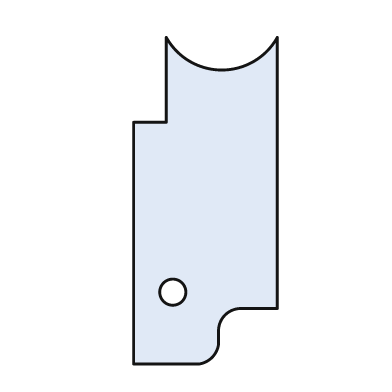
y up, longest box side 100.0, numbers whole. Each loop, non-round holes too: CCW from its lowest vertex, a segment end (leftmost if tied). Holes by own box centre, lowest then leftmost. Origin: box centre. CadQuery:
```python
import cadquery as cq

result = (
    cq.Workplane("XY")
    .moveTo(-22.0, -50.0)
    .lineTo(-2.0, -50.0)
    .threePointArc((2.0, -48.0), (4.0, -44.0))
    .lineTo(4.0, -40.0)
    .threePointArc((6.0, -35.0), (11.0, -33.0))
    .lineTo(22.0, -33.0)
    .lineTo(22.0, 50.0)
    .threePointArc((5.0, 40.0), (-12.0, 50.0))
    .lineTo(-12.0, 24.0)
    .lineTo(-22.0, 24.0)
    .close()
    .moveTo(-10.0, -28.0)
    .circle(4.0)
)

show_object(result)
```